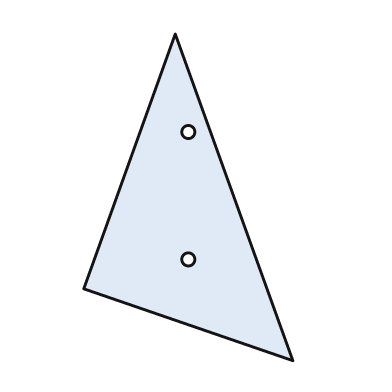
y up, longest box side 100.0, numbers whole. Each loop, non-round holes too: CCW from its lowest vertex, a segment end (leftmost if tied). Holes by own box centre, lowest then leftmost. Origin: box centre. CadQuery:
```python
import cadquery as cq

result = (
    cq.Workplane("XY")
    .moveTo(32.0, -50.0)
    .lineTo(-4.0, 50.0)
    .lineTo(-32.0, -28.0)
    .close()
    .moveTo(0.0, -19.0)
    .circle(2.0)
    .moveTo(0.0, 20.0)
    .circle(2.0)
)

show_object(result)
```